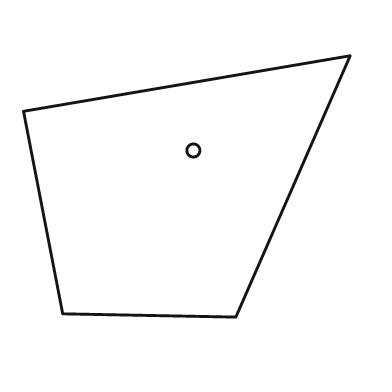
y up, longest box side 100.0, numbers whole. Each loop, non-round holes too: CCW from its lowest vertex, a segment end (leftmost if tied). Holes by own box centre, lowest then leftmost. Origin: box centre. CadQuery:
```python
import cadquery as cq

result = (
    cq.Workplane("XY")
    .moveTo(15.0, -40.0)
    .lineTo(50.0, 40.0)
    .lineTo(-50.0, 23.0)
    .lineTo(-38.0, -39.0)
    .close()
    .moveTo(2.0, 11.0)
    .circle(2.0)
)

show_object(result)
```